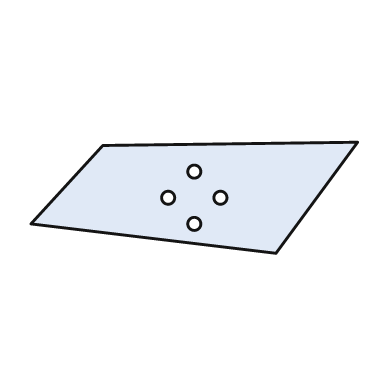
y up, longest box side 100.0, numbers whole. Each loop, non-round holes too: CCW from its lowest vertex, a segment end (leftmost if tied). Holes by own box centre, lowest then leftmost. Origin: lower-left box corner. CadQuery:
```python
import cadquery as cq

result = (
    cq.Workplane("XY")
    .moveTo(75.0, 0.0)
    .lineTo(100.0, 34.0)
    .lineTo(22.0, 33.0)
    .lineTo(0.0, 9.0)
    .close()
    .moveTo(50.0, 9.0)
    .circle(2.0)
    .moveTo(42.0, 17.0)
    .circle(2.0)
    .moveTo(58.0, 17.0)
    .circle(2.0)
    .moveTo(50.0, 25.0)
    .circle(2.0)
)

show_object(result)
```